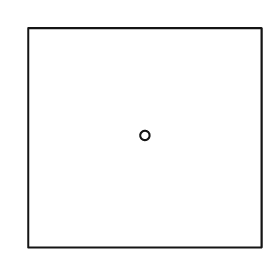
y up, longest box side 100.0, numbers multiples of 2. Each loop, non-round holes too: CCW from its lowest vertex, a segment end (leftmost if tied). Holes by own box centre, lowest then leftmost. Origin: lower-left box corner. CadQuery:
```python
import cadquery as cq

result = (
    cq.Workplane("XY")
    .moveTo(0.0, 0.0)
    .lineTo(100.0, 0.0)
    .lineTo(100.0, 94.0)
    .lineTo(0.0, 94.0)
    .close()
    .moveTo(50.0, 48.0)
    .circle(2.0)
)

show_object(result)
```